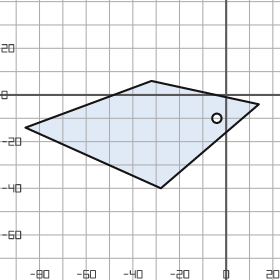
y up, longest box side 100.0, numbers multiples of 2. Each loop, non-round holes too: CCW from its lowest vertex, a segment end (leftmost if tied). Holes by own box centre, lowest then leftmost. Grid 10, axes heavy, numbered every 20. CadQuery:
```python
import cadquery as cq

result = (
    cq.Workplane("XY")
    .moveTo(-28.0, -40.0)
    .lineTo(14.0, -4.0)
    .lineTo(-32.0, 6.0)
    .lineTo(-86.0, -14.0)
    .close()
    .moveTo(-4.0, -10.0)
    .circle(2.0)
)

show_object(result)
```